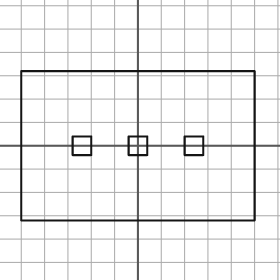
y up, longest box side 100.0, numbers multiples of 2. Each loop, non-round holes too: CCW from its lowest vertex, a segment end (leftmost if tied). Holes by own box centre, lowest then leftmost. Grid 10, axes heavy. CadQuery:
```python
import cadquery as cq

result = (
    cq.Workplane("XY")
    .moveTo(-50.0, -32.0)
    .lineTo(50.0, -32.0)
    .lineTo(50.0, 32.0)
    .lineTo(-50.0, 32.0)
    .close()
    .moveTo(-28.0, -4.0)
    .lineTo(-20.0, -4.0)
    .lineTo(-20.0, 4.0)
    .lineTo(-28.0, 4.0)
    .close()
    .moveTo(-4.0, -4.0)
    .lineTo(4.0, -4.0)
    .lineTo(4.0, 4.0)
    .lineTo(-4.0, 4.0)
    .close()
    .moveTo(20.0, -4.0)
    .lineTo(28.0, -4.0)
    .lineTo(28.0, 4.0)
    .lineTo(20.0, 4.0)
    .close()
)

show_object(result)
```